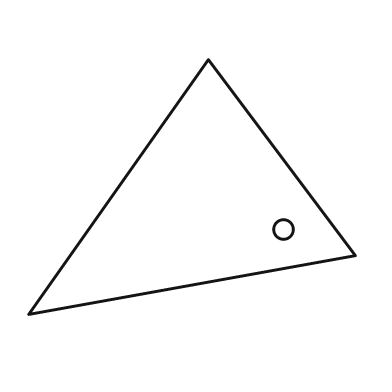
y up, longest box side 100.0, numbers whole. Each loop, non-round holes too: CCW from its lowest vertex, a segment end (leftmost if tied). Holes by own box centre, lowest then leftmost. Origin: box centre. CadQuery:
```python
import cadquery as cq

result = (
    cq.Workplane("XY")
    .moveTo(-50.0, -39.0)
    .lineTo(50.0, -21.0)
    .lineTo(5.0, 39.0)
    .close()
    .moveTo(28.0, -13.0)
    .circle(3.0)
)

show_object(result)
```